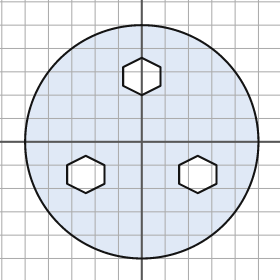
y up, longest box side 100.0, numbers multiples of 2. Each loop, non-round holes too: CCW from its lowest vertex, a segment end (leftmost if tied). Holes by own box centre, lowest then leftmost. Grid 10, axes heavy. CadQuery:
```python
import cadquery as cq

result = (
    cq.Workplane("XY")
    .moveTo(0.0, 0.0)
    .circle(50.0)
    .moveTo(-24.0, -22.0)
    .lineTo(-16.0, -18.0)
    .lineTo(-16.0, -10.0)
    .lineTo(-24.0, -6.0)
    .lineTo(-32.0, -10.0)
    .lineTo(-32.0, -18.0)
    .close()
    .moveTo(24.0, -22.0)
    .lineTo(32.0, -18.0)
    .lineTo(32.0, -10.0)
    .lineTo(24.0, -6.0)
    .lineTo(16.0, -10.0)
    .lineTo(16.0, -18.0)
    .close()
    .moveTo(0.0, 20.0)
    .lineTo(8.0, 24.0)
    .lineTo(8.0, 32.0)
    .lineTo(0.0, 36.0)
    .lineTo(-8.0, 32.0)
    .lineTo(-8.0, 24.0)
    .close()
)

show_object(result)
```